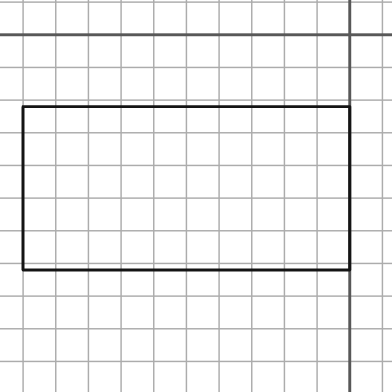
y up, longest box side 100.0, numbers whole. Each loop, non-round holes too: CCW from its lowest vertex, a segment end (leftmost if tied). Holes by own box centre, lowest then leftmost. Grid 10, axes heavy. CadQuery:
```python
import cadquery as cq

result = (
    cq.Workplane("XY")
    .moveTo(-100.0, -72.0)
    .lineTo(0.0, -72.0)
    .lineTo(0.0, -22.0)
    .lineTo(-100.0, -22.0)
    .close()
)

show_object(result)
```